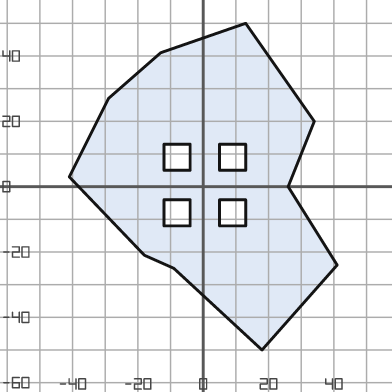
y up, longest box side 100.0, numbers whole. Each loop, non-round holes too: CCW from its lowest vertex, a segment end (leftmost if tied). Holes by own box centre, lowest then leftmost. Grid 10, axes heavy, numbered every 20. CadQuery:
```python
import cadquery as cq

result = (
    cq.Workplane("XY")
    .moveTo(18.0, -50.0)
    .lineTo(41.0, -24.0)
    .lineTo(26.0, 0.0)
    .lineTo(34.0, 20.0)
    .lineTo(13.0, 50.0)
    .lineTo(-13.0, 41.0)
    .lineTo(-29.0, 27.0)
    .lineTo(-41.0, 3.0)
    .lineTo(-18.0, -21.0)
    .lineTo(-9.0, -25.0)
    .close()
    .moveTo(-12.0, -12.0)
    .lineTo(-4.0, -12.0)
    .lineTo(-4.0, -4.0)
    .lineTo(-12.0, -4.0)
    .close()
    .moveTo(5.0, -12.0)
    .lineTo(13.0, -12.0)
    .lineTo(13.0, -4.0)
    .lineTo(5.0, -4.0)
    .close()
    .moveTo(-12.0, 5.0)
    .lineTo(-4.0, 5.0)
    .lineTo(-4.0, 13.0)
    .lineTo(-12.0, 13.0)
    .close()
    .moveTo(5.0, 5.0)
    .lineTo(13.0, 5.0)
    .lineTo(13.0, 13.0)
    .lineTo(5.0, 13.0)
    .close()
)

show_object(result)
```